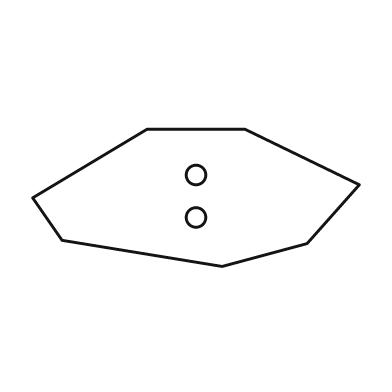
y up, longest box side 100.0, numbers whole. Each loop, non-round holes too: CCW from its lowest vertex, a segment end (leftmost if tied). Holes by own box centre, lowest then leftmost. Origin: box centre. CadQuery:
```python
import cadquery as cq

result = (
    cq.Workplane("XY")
    .moveTo(8.0, -21.0)
    .lineTo(34.0, -14.0)
    .lineTo(50.0, 4.0)
    .lineTo(15.0, 21.0)
    .lineTo(-15.0, 21.0)
    .lineTo(-50.0, 0.0)
    .lineTo(-41.0, -13.0)
    .close()
    .moveTo(0.0, -6.0)
    .circle(3.0)
    .moveTo(0.0, 7.0)
    .circle(3.0)
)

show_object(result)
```